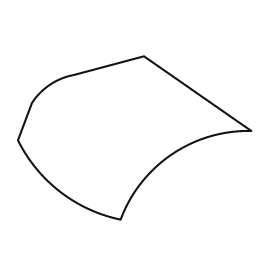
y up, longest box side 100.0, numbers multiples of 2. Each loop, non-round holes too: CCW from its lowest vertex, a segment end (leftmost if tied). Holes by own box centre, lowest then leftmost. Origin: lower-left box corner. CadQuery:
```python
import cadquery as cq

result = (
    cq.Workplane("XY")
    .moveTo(44.0, 0.0)
    .threePointArc((66.0, 28.0), (100.0, 38.0))
    .lineTo(54.0, 70.0)
    .lineTo(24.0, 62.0)
    .threePointArc((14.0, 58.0), (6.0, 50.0))
    .lineTo(0.0, 34.0)
    .threePointArc((18.0, 12.0), (44.0, 0.0))
    .close()
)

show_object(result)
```